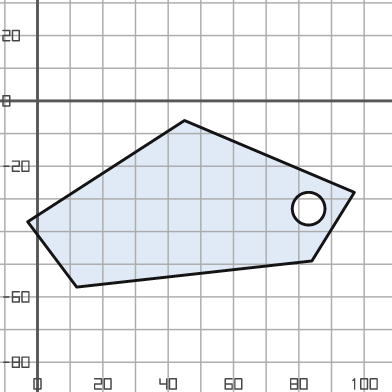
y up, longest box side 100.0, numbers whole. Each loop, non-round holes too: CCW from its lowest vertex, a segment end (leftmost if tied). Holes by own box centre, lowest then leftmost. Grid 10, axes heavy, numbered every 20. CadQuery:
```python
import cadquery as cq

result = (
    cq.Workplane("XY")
    .moveTo(12.0, -57.0)
    .lineTo(84.0, -49.0)
    .lineTo(97.0, -28.0)
    .lineTo(45.0, -6.0)
    .lineTo(-3.0, -37.0)
    .close()
    .moveTo(83.0, -33.0)
    .circle(5.0)
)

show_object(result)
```